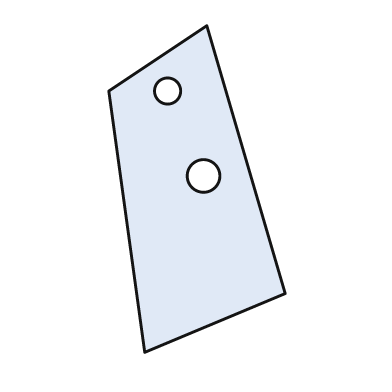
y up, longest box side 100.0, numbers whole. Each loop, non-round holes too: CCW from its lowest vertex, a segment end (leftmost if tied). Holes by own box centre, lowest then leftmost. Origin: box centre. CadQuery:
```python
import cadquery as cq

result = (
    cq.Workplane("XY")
    .moveTo(-16.0, -50.0)
    .lineTo(27.0, -32.0)
    .lineTo(3.0, 50.0)
    .lineTo(-27.0, 30.0)
    .close()
    .moveTo(2.0, 4.0)
    .circle(5.0)
    .moveTo(-9.0, 30.0)
    .circle(4.0)
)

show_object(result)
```